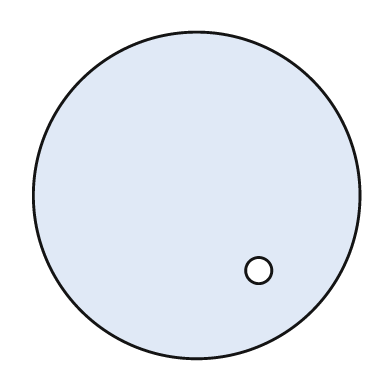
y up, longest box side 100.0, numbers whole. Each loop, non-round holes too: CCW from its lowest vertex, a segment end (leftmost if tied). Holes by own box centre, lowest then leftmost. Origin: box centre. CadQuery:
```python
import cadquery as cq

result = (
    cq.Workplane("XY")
    .moveTo(0.0, 0.0)
    .circle(50.0)
    .moveTo(19.0, -23.0)
    .circle(4.0)
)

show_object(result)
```